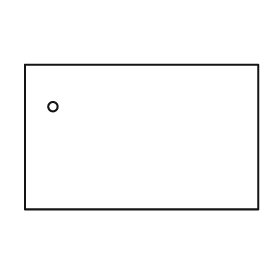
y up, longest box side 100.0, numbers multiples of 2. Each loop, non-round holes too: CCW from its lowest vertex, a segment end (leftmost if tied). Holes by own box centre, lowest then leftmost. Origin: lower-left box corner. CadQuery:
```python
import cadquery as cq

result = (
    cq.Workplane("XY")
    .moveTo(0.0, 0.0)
    .lineTo(100.0, 0.0)
    .lineTo(100.0, 62.0)
    .lineTo(0.0, 62.0)
    .close()
    .moveTo(12.0, 44.0)
    .circle(2.0)
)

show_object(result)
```